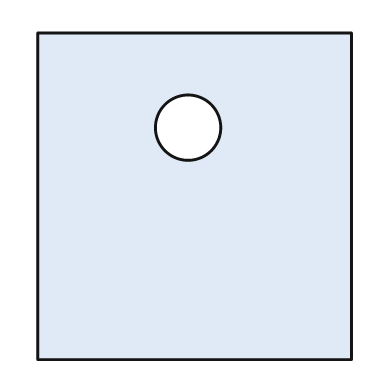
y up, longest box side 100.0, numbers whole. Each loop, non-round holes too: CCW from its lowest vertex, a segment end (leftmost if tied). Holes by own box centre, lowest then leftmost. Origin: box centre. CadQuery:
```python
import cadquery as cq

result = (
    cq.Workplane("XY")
    .moveTo(-48.0, -50.0)
    .lineTo(48.0, -50.0)
    .lineTo(48.0, 50.0)
    .lineTo(-48.0, 50.0)
    .close()
    .moveTo(-2.0, 21.0)
    .circle(10.0)
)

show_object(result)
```